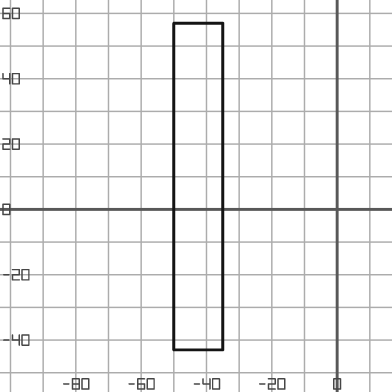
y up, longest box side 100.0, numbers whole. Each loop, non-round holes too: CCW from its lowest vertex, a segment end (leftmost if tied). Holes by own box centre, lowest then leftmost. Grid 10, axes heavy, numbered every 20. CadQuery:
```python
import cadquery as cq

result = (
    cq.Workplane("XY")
    .moveTo(-50.0, -43.0)
    .lineTo(-35.0, -43.0)
    .lineTo(-35.0, 57.0)
    .lineTo(-50.0, 57.0)
    .close()
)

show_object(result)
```